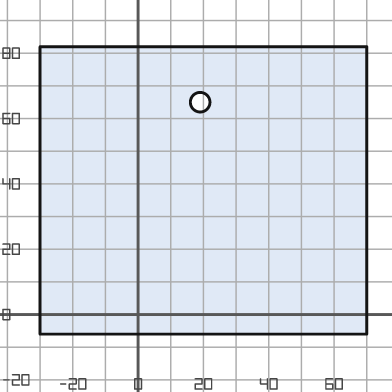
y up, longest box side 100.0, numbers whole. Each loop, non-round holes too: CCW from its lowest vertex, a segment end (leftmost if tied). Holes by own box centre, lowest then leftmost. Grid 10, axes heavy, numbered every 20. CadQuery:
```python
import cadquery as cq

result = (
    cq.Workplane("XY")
    .moveTo(-30.0, -6.0)
    .lineTo(70.0, -6.0)
    .lineTo(70.0, 82.0)
    .lineTo(-30.0, 82.0)
    .close()
    .moveTo(19.0, 65.0)
    .circle(3.0)
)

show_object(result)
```